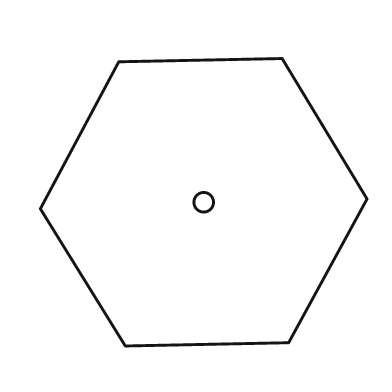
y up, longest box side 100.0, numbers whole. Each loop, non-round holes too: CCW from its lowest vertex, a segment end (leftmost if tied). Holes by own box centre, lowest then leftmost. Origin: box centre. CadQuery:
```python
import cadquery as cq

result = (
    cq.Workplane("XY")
    .moveTo(-24.0, -44.0)
    .lineTo(26.0, -43.0)
    .lineTo(50.0, 1.0)
    .lineTo(24.0, 44.0)
    .lineTo(-26.0, 43.0)
    .lineTo(-50.0, -2.0)
    .close()
    .moveTo(0.0, 0.0)
    .circle(3.0)
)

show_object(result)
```